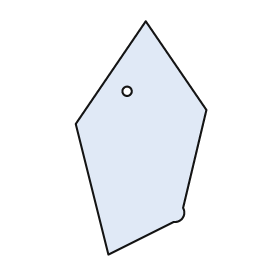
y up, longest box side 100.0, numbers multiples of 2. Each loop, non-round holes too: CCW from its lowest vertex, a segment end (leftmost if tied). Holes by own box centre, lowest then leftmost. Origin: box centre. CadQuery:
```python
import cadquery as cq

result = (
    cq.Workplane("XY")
    .moveTo(-14.0, -50.0)
    .lineTo(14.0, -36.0)
    .threePointArc((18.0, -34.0), (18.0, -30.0))
    .lineTo(28.0, 12.0)
    .lineTo(2.0, 50.0)
    .lineTo(-28.0, 6.0)
    .close()
    .moveTo(-6.0, 20.0)
    .circle(2.0)
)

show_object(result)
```